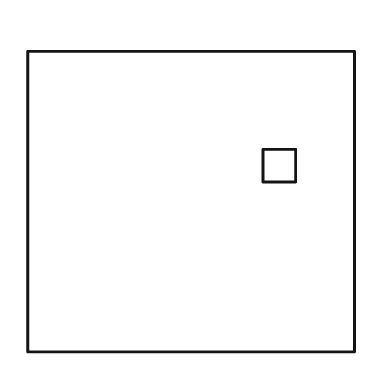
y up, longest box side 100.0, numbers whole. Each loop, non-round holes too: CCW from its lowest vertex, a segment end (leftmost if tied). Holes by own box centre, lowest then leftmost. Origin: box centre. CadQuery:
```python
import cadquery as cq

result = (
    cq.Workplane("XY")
    .moveTo(-50.0, -46.0)
    .lineTo(50.0, -46.0)
    .lineTo(50.0, 46.0)
    .lineTo(-50.0, 46.0)
    .close()
    .moveTo(22.0, 6.0)
    .lineTo(32.0, 6.0)
    .lineTo(32.0, 16.0)
    .lineTo(22.0, 16.0)
    .close()
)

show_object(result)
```